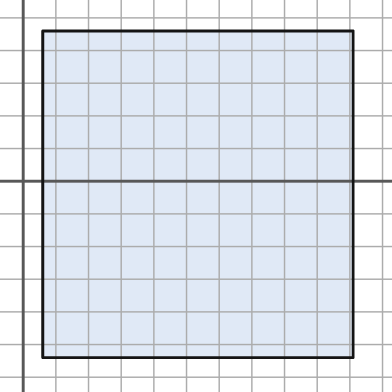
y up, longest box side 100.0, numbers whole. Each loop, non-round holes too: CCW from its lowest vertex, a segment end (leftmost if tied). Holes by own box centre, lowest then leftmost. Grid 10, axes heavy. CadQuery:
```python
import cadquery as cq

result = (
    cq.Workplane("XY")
    .moveTo(6.0, -54.0)
    .lineTo(101.0, -54.0)
    .lineTo(101.0, 46.0)
    .lineTo(6.0, 46.0)
    .close()
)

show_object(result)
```